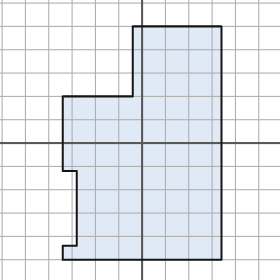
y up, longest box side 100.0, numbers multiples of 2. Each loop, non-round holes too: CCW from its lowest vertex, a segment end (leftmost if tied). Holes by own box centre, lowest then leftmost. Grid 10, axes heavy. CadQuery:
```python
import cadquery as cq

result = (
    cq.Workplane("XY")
    .moveTo(-34.0, -50.0)
    .lineTo(34.0, -50.0)
    .lineTo(34.0, 50.0)
    .lineTo(-4.0, 50.0)
    .lineTo(-4.0, 20.0)
    .lineTo(-34.0, 20.0)
    .lineTo(-34.0, -12.0)
    .lineTo(-28.0, -12.0)
    .lineTo(-28.0, -44.0)
    .lineTo(-34.0, -44.0)
    .close()
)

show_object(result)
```